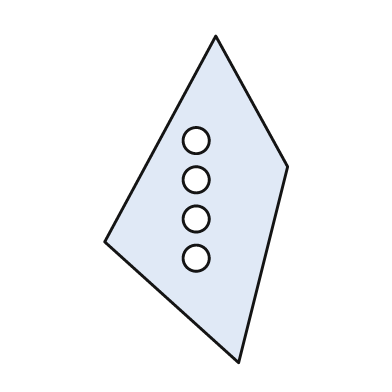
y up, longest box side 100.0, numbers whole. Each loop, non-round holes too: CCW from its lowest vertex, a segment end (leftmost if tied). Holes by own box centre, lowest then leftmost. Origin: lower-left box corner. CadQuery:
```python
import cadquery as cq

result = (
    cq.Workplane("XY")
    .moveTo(41.0, 0.0)
    .lineTo(56.0, 60.0)
    .lineTo(34.0, 100.0)
    .lineTo(0.0, 37.0)
    .close()
    .moveTo(28.0, 32.0)
    .circle(4.0)
    .moveTo(28.0, 44.0)
    .circle(4.0)
    .moveTo(28.0, 56.0)
    .circle(4.0)
    .moveTo(28.0, 68.0)
    .circle(4.0)
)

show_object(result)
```